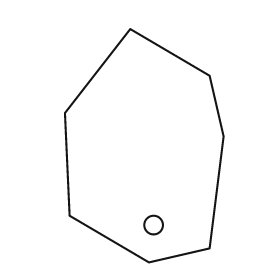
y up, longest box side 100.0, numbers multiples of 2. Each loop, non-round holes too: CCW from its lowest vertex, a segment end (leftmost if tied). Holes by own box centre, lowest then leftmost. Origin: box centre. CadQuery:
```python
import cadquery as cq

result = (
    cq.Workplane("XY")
    .moveTo(2.0, -50.0)
    .lineTo(28.0, -44.0)
    .lineTo(34.0, 4.0)
    .lineTo(28.0, 30.0)
    .lineTo(-6.0, 50.0)
    .lineTo(-34.0, 14.0)
    .lineTo(-32.0, -30.0)
    .close()
    .moveTo(4.0, -34.0)
    .circle(4.0)
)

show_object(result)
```